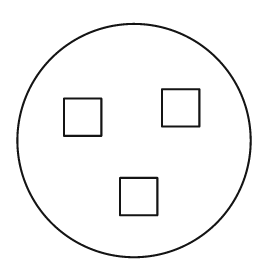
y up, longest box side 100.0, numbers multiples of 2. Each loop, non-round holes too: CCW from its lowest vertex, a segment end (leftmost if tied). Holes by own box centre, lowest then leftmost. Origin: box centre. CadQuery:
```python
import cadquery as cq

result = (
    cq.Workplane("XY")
    .moveTo(0.0, 0.0)
    .circle(50.0)
    .moveTo(-6.0, -32.0)
    .lineTo(10.0, -32.0)
    .lineTo(10.0, -16.0)
    .lineTo(-6.0, -16.0)
    .close()
    .moveTo(-30.0, 2.0)
    .lineTo(-14.0, 2.0)
    .lineTo(-14.0, 18.0)
    .lineTo(-30.0, 18.0)
    .close()
    .moveTo(12.0, 6.0)
    .lineTo(28.0, 6.0)
    .lineTo(28.0, 22.0)
    .lineTo(12.0, 22.0)
    .close()
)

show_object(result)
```